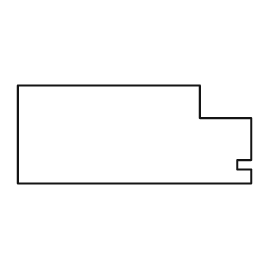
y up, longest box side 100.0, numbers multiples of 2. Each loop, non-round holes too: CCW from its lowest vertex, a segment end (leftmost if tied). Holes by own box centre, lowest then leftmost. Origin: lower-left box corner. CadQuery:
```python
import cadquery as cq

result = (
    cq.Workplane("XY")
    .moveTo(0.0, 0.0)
    .lineTo(100.0, 0.0)
    .lineTo(100.0, 6.0)
    .lineTo(94.0, 6.0)
    .lineTo(94.0, 10.0)
    .lineTo(100.0, 10.0)
    .lineTo(100.0, 28.0)
    .lineTo(78.0, 28.0)
    .lineTo(78.0, 42.0)
    .lineTo(0.0, 42.0)
    .close()
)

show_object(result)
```